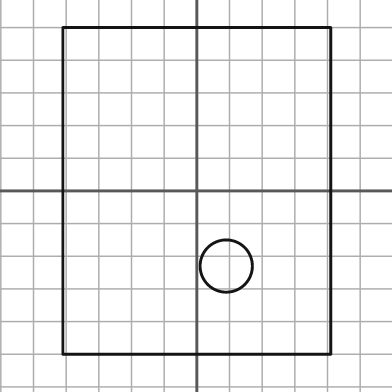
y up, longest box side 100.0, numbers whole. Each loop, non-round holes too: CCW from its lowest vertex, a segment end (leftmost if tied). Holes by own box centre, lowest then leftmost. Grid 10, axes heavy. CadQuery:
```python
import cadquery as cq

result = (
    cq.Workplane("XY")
    .moveTo(-41.0, -50.0)
    .lineTo(41.0, -50.0)
    .lineTo(41.0, 50.0)
    .lineTo(-41.0, 50.0)
    .close()
    .moveTo(9.0, -23.0)
    .circle(8.0)
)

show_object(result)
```